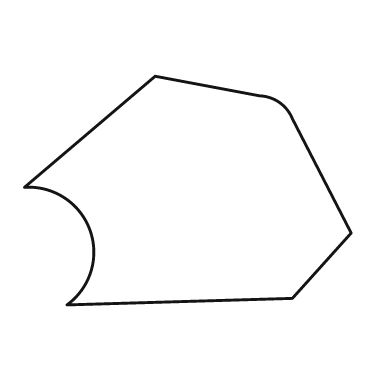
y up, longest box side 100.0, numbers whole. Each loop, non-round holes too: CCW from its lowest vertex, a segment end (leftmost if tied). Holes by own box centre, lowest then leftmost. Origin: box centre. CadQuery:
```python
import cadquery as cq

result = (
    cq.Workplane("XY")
    .moveTo(-37.0, -35.0)
    .lineTo(32.0, -33.0)
    .lineTo(50.0, -13.0)
    .lineTo(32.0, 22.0)
    .threePointArc((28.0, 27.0), (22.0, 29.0))
    .lineTo(-10.0, 35.0)
    .lineTo(-50.0, 1.0)
    .threePointArc((-30.0, -12.0), (-37.0, -35.0))
    .close()
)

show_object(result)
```